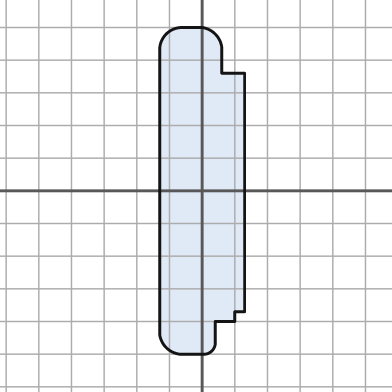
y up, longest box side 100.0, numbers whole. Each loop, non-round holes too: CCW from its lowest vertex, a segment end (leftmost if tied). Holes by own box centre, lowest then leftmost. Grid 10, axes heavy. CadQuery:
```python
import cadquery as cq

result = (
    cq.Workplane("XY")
    .moveTo(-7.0, -50.0)
    .lineTo(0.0, -50.0)
    .threePointArc((3.0, -49.0), (4.0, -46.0))
    .lineTo(4.0, -40.0)
    .lineTo(10.0, -40.0)
    .lineTo(10.0, -37.0)
    .lineTo(13.0, -37.0)
    .lineTo(13.0, 36.0)
    .lineTo(6.0, 36.0)
    .lineTo(6.0, 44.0)
    .threePointArc((4.0, 48.0), (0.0, 50.0))
    .lineTo(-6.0, 50.0)
    .threePointArc((-11.0, 48.0), (-13.0, 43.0))
    .lineTo(-13.0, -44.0)
    .threePointArc((-11.0, -48.0), (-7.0, -50.0))
    .close()
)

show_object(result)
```